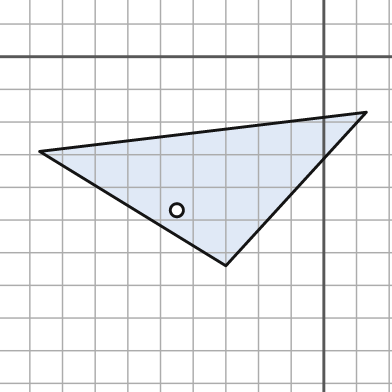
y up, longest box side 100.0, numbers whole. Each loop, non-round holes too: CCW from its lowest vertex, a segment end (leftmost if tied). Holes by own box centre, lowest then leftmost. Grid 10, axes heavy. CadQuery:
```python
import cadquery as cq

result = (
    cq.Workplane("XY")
    .moveTo(-30.0, -64.0)
    .lineTo(13.0, -17.0)
    .lineTo(-87.0, -29.0)
    .close()
    .moveTo(-45.0, -47.0)
    .circle(2.0)
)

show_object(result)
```